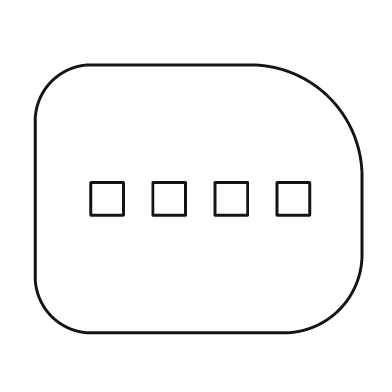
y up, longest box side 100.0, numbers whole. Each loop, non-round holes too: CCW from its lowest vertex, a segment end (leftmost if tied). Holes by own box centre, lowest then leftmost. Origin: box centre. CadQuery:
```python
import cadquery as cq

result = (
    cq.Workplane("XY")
    .moveTo(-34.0, -41.0)
    .lineTo(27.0, -41.0)
    .threePointArc((43.0, -34.0), (50.0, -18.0))
    .lineTo(50.0, 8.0)
    .threePointArc((40.0, 31.0), (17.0, 41.0))
    .lineTo(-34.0, 41.0)
    .threePointArc((-45.0, 36.0), (-50.0, 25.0))
    .lineTo(-50.0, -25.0)
    .threePointArc((-45.0, -36.0), (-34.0, -41.0))
    .close()
    .moveTo(-33.0, -5.0)
    .lineTo(-23.0, -5.0)
    .lineTo(-23.0, 5.0)
    .lineTo(-33.0, 5.0)
    .close()
    .moveTo(-14.0, -5.0)
    .lineTo(-4.0, -5.0)
    .lineTo(-4.0, 5.0)
    .lineTo(-14.0, 5.0)
    .close()
    .moveTo(5.0, -5.0)
    .lineTo(15.0, -5.0)
    .lineTo(15.0, 5.0)
    .lineTo(5.0, 5.0)
    .close()
    .moveTo(24.0, -5.0)
    .lineTo(34.0, -5.0)
    .lineTo(34.0, 5.0)
    .lineTo(24.0, 5.0)
    .close()
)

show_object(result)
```